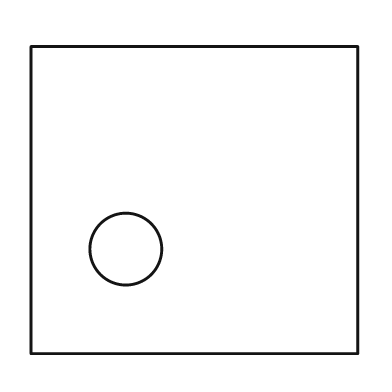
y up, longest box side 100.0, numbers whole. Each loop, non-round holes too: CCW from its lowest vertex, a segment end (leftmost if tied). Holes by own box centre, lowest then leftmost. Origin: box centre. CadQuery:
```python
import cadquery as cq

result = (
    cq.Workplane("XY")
    .moveTo(-50.0, -47.0)
    .lineTo(50.0, -47.0)
    .lineTo(50.0, 47.0)
    .lineTo(-50.0, 47.0)
    .close()
    .moveTo(-21.0, -15.0)
    .circle(11.0)
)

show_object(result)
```